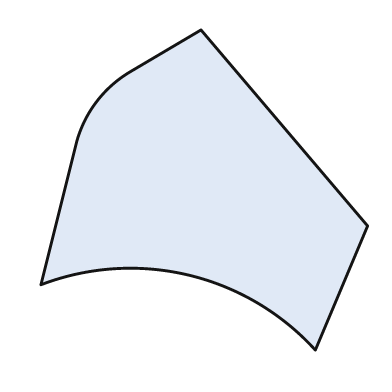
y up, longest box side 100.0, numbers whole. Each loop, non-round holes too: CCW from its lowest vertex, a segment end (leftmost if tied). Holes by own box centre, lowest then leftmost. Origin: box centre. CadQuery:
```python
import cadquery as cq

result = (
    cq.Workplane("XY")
    .moveTo(34.0, -49.0)
    .lineTo(50.0, -11.0)
    .lineTo(-1.0, 49.0)
    .lineTo(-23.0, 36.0)
    .threePointArc((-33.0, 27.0), (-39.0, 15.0))
    .lineTo(-50.0, -29.0)
    .threePointArc((-5.0, -26.0), (34.0, -49.0))
    .close()
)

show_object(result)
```